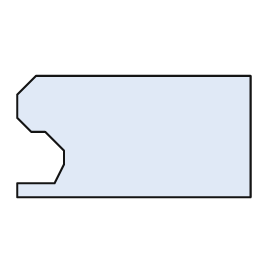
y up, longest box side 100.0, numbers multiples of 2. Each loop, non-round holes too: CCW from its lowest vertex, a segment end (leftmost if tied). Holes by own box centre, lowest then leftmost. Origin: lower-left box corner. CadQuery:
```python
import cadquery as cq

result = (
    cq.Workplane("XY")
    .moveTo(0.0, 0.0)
    .lineTo(100.0, 0.0)
    .lineTo(100.0, 52.0)
    .lineTo(8.0, 52.0)
    .lineTo(0.0, 44.0)
    .lineTo(0.0, 34.0)
    .lineTo(6.0, 28.0)
    .lineTo(12.0, 28.0)
    .lineTo(20.0, 20.0)
    .lineTo(20.0, 14.0)
    .lineTo(16.0, 6.0)
    .lineTo(0.0, 6.0)
    .close()
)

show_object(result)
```